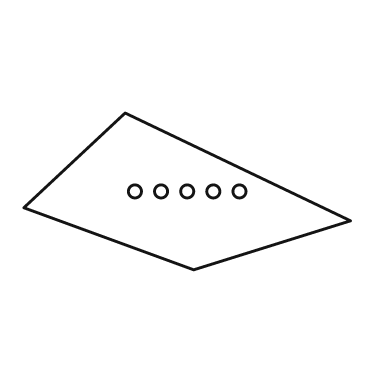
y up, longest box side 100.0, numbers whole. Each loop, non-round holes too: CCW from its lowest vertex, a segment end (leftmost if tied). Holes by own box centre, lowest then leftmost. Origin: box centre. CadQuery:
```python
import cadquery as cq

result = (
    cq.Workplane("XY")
    .moveTo(2.0, -24.0)
    .lineTo(50.0, -9.0)
    .lineTo(-19.0, 24.0)
    .lineTo(-50.0, -5.0)
    .close()
    .moveTo(-16.0, 0.0)
    .circle(2.0)
    .moveTo(-8.0, 0.0)
    .circle(2.0)
    .moveTo(0.0, 0.0)
    .circle(2.0)
    .moveTo(8.0, 0.0)
    .circle(2.0)
    .moveTo(16.0, 0.0)
    .circle(2.0)
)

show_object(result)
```